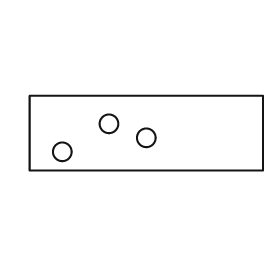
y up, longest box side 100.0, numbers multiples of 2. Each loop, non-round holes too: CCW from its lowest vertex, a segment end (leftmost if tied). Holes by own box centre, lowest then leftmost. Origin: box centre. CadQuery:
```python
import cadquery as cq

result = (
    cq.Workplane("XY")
    .moveTo(-50.0, -16.0)
    .lineTo(50.0, -16.0)
    .lineTo(50.0, 16.0)
    .lineTo(-50.0, 16.0)
    .close()
    .moveTo(-36.0, -8.0)
    .circle(4.0)
    .moveTo(0.0, -2.0)
    .circle(4.0)
    .moveTo(-16.0, 4.0)
    .circle(4.0)
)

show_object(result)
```